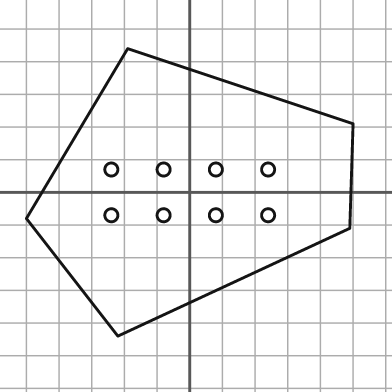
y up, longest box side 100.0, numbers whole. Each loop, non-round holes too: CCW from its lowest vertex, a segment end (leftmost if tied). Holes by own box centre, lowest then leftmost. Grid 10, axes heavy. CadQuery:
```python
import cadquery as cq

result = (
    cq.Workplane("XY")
    .moveTo(-22.0, -44.0)
    .lineTo(49.0, -11.0)
    .lineTo(50.0, 21.0)
    .lineTo(-19.0, 44.0)
    .lineTo(-50.0, -8.0)
    .close()
    .moveTo(-24.0, -7.0)
    .circle(2.0)
    .moveTo(-8.0, -7.0)
    .circle(2.0)
    .moveTo(8.0, -7.0)
    .circle(2.0)
    .moveTo(24.0, -7.0)
    .circle(2.0)
    .moveTo(-24.0, 7.0)
    .circle(2.0)
    .moveTo(-8.0, 7.0)
    .circle(2.0)
    .moveTo(8.0, 7.0)
    .circle(2.0)
    .moveTo(24.0, 7.0)
    .circle(2.0)
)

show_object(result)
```